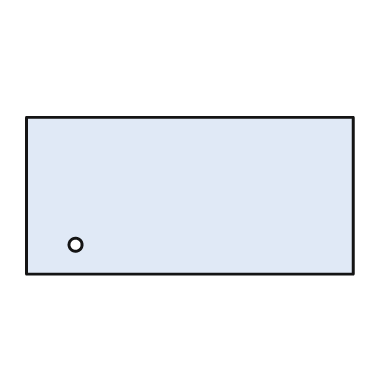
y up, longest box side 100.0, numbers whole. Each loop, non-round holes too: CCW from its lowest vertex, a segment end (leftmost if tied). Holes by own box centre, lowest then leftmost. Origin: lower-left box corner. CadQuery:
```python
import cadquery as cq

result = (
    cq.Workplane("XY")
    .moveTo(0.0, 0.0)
    .lineTo(100.0, 0.0)
    .lineTo(100.0, 48.0)
    .lineTo(0.0, 48.0)
    .close()
    .moveTo(15.0, 9.0)
    .circle(2.0)
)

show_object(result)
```